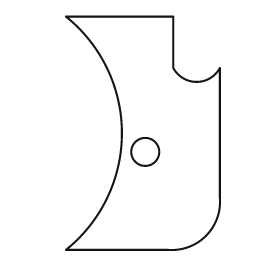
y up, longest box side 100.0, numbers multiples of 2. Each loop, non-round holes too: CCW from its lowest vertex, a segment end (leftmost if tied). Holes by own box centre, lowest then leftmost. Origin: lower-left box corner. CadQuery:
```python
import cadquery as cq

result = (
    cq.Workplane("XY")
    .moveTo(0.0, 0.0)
    .lineTo(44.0, 0.0)
    .threePointArc((60.0, 6.0), (66.0, 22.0))
    .lineTo(66.0, 78.0)
    .threePointArc((56.0, 72.0), (46.0, 78.0))
    .lineTo(46.0, 100.0)
    .lineTo(0.0, 100.0)
    .threePointArc((24.0, 50.0), (0.0, 0.0))
    .close()
    .moveTo(34.0, 42.0)
    .circle(6.0)
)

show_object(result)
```